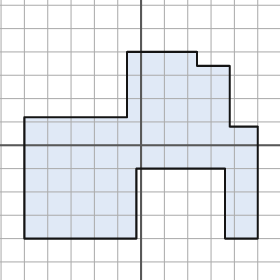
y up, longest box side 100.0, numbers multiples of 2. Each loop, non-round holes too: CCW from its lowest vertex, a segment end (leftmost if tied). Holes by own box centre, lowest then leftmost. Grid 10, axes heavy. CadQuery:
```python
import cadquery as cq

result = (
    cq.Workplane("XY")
    .moveTo(-50.0, -40.0)
    .lineTo(-2.0, -40.0)
    .lineTo(-2.0, -10.0)
    .lineTo(36.0, -10.0)
    .lineTo(36.0, -40.0)
    .lineTo(50.0, -40.0)
    .lineTo(50.0, 8.0)
    .lineTo(38.0, 8.0)
    .lineTo(38.0, 34.0)
    .lineTo(24.0, 34.0)
    .lineTo(24.0, 40.0)
    .lineTo(-6.0, 40.0)
    .lineTo(-6.0, 12.0)
    .lineTo(-50.0, 12.0)
    .close()
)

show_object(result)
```